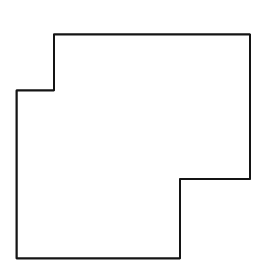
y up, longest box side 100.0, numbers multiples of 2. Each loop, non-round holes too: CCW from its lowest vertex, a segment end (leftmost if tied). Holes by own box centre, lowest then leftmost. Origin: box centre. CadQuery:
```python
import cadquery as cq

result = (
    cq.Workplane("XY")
    .moveTo(-50.0, -48.0)
    .lineTo(20.0, -48.0)
    .lineTo(20.0, -14.0)
    .lineTo(50.0, -14.0)
    .lineTo(50.0, 48.0)
    .lineTo(-34.0, 48.0)
    .lineTo(-34.0, 24.0)
    .lineTo(-50.0, 24.0)
    .close()
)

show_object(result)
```